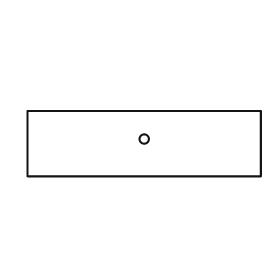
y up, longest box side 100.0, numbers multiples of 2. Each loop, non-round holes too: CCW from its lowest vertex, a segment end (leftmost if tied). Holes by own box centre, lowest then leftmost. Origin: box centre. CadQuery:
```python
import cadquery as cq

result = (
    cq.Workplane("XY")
    .moveTo(-50.0, -14.0)
    .lineTo(50.0, -14.0)
    .lineTo(50.0, 14.0)
    .lineTo(-50.0, 14.0)
    .close()
    .moveTo(0.0, 2.0)
    .circle(2.0)
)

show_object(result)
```